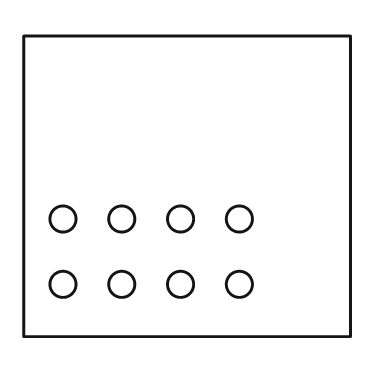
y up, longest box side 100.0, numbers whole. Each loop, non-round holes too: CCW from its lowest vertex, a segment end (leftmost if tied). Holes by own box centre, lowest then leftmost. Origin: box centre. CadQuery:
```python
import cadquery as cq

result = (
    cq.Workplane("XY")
    .moveTo(-50.0, -46.0)
    .lineTo(50.0, -46.0)
    .lineTo(50.0, 46.0)
    .lineTo(-50.0, 46.0)
    .close()
    .moveTo(-38.0, -30.0)
    .circle(4.0)
    .moveTo(-20.0, -30.0)
    .circle(4.0)
    .moveTo(-2.0, -30.0)
    .circle(4.0)
    .moveTo(16.0, -30.0)
    .circle(4.0)
    .moveTo(-38.0, -10.0)
    .circle(4.0)
    .moveTo(-20.0, -10.0)
    .circle(4.0)
    .moveTo(-2.0, -10.0)
    .circle(4.0)
    .moveTo(16.0, -10.0)
    .circle(4.0)
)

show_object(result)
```